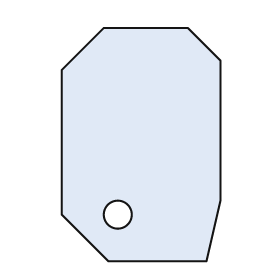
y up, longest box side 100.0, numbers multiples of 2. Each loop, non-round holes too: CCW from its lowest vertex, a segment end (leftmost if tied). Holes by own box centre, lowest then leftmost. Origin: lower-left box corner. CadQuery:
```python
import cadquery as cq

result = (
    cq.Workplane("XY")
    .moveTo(20.0, 0.0)
    .lineTo(62.0, 0.0)
    .lineTo(68.0, 26.0)
    .lineTo(68.0, 86.0)
    .lineTo(54.0, 100.0)
    .lineTo(18.0, 100.0)
    .lineTo(0.0, 82.0)
    .lineTo(0.0, 20.0)
    .close()
    .moveTo(24.0, 20.0)
    .circle(6.0)
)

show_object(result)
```